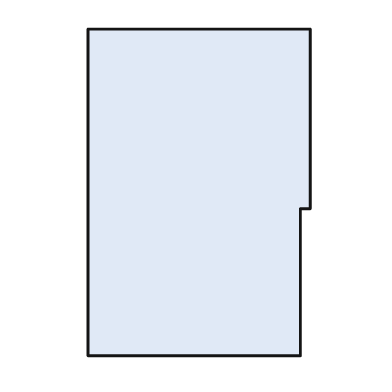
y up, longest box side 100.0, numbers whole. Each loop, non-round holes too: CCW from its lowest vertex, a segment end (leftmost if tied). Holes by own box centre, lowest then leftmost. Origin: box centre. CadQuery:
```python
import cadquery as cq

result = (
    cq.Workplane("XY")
    .moveTo(-34.0, -50.0)
    .lineTo(31.0, -50.0)
    .lineTo(31.0, -5.0)
    .lineTo(34.0, -5.0)
    .lineTo(34.0, 50.0)
    .lineTo(-34.0, 50.0)
    .close()
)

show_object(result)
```